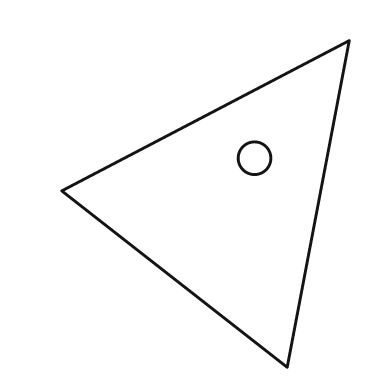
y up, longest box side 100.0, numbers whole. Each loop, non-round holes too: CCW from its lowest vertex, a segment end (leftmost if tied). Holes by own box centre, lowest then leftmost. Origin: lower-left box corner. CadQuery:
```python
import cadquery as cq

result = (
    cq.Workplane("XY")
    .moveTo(69.0, 0.0)
    .lineTo(88.0, 100.0)
    .lineTo(0.0, 54.0)
    .close()
    .moveTo(59.0, 64.0)
    .circle(5.0)
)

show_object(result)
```